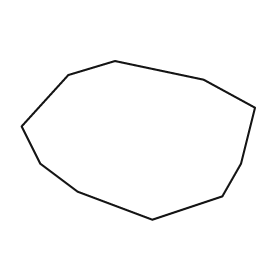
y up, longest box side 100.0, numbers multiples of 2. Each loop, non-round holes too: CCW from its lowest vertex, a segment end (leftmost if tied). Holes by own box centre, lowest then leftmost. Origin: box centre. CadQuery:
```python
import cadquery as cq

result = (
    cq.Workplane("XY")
    .moveTo(6.0, -34.0)
    .lineTo(36.0, -24.0)
    .lineTo(44.0, -10.0)
    .lineTo(50.0, 14.0)
    .lineTo(28.0, 26.0)
    .lineTo(-10.0, 34.0)
    .lineTo(-30.0, 28.0)
    .lineTo(-50.0, 6.0)
    .lineTo(-42.0, -10.0)
    .lineTo(-26.0, -22.0)
    .close()
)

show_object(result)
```